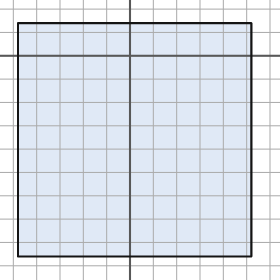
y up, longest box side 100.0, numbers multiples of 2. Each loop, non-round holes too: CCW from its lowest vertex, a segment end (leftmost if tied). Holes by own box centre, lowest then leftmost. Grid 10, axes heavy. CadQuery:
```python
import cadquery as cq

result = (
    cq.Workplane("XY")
    .moveTo(-48.0, -86.0)
    .lineTo(52.0, -86.0)
    .lineTo(52.0, 14.0)
    .lineTo(-48.0, 14.0)
    .close()
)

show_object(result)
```